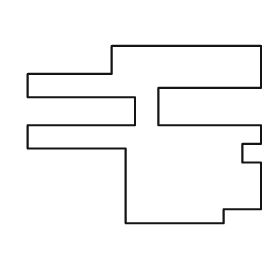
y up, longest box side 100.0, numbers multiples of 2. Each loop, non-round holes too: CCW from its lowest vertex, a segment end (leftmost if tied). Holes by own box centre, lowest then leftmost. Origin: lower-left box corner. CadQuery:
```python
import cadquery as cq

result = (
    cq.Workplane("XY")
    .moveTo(42.0, 0.0)
    .lineTo(84.0, 0.0)
    .lineTo(84.0, 6.0)
    .lineTo(100.0, 6.0)
    .lineTo(100.0, 26.0)
    .lineTo(92.0, 26.0)
    .lineTo(92.0, 34.0)
    .lineTo(100.0, 34.0)
    .lineTo(100.0, 42.0)
    .lineTo(56.0, 42.0)
    .lineTo(56.0, 58.0)
    .lineTo(100.0, 58.0)
    .lineTo(100.0, 76.0)
    .lineTo(36.0, 76.0)
    .lineTo(36.0, 64.0)
    .lineTo(0.0, 64.0)
    .lineTo(0.0, 54.0)
    .lineTo(46.0, 54.0)
    .lineTo(46.0, 42.0)
    .lineTo(0.0, 42.0)
    .lineTo(0.0, 32.0)
    .lineTo(42.0, 32.0)
    .close()
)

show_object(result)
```